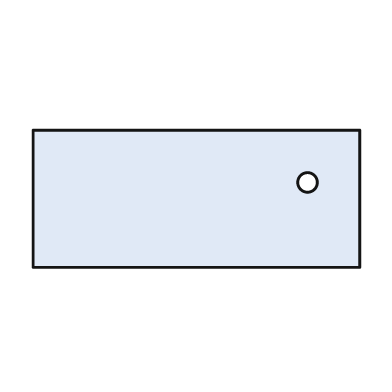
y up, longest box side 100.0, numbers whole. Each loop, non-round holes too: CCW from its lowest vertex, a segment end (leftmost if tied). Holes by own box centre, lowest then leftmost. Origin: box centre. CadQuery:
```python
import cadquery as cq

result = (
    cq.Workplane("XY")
    .moveTo(-50.0, -21.0)
    .lineTo(50.0, -21.0)
    .lineTo(50.0, 21.0)
    .lineTo(-50.0, 21.0)
    .close()
    .moveTo(34.0, 5.0)
    .circle(3.0)
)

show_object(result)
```